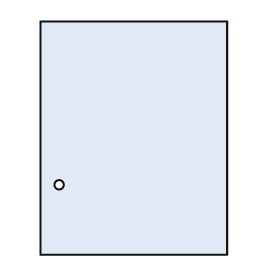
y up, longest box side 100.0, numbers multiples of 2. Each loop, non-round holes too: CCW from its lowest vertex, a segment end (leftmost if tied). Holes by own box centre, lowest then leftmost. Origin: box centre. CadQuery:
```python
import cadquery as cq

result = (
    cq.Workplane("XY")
    .moveTo(-40.0, -50.0)
    .lineTo(40.0, -50.0)
    .lineTo(40.0, 50.0)
    .lineTo(-40.0, 50.0)
    .close()
    .moveTo(-32.0, -20.0)
    .circle(2.0)
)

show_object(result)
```